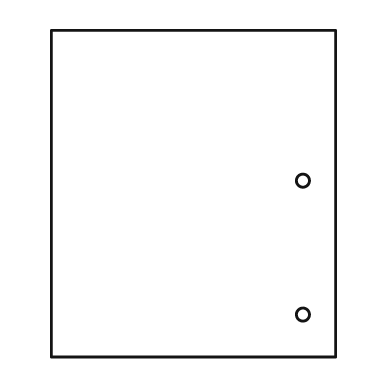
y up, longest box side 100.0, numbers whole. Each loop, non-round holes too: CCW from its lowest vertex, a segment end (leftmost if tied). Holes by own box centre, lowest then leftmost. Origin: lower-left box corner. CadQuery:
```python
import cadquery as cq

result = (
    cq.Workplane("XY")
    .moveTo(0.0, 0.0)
    .lineTo(87.0, 0.0)
    .lineTo(87.0, 100.0)
    .lineTo(0.0, 100.0)
    .close()
    .moveTo(77.0, 13.0)
    .circle(2.0)
    .moveTo(77.0, 54.0)
    .circle(2.0)
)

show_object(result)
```